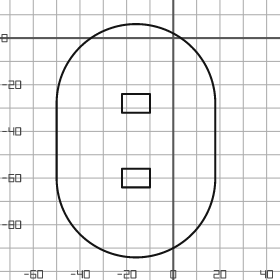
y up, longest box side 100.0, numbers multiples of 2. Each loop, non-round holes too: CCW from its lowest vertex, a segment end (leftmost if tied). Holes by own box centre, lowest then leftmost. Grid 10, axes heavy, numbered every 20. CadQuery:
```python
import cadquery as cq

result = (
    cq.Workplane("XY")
    .moveTo(-50.0, -60.0)
    .threePointArc((-16.0, -94.0), (18.0, -60.0))
    .lineTo(18.0, -28.0)
    .threePointArc((-16.0, 6.0), (-50.0, -28.0))
    .close()
    .moveTo(-22.0, -64.0)
    .lineTo(-10.0, -64.0)
    .lineTo(-10.0, -56.0)
    .lineTo(-22.0, -56.0)
    .close()
    .moveTo(-22.0, -32.0)
    .lineTo(-10.0, -32.0)
    .lineTo(-10.0, -24.0)
    .lineTo(-22.0, -24.0)
    .close()
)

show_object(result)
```